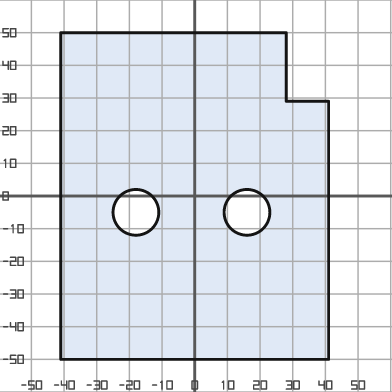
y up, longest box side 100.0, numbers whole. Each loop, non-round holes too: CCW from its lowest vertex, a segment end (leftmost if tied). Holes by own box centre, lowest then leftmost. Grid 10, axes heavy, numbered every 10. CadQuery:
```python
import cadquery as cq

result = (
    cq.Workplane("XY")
    .moveTo(-41.0, -50.0)
    .lineTo(41.0, -50.0)
    .lineTo(41.0, 29.0)
    .lineTo(28.0, 29.0)
    .lineTo(28.0, 50.0)
    .lineTo(-41.0, 50.0)
    .close()
    .moveTo(-18.0, -5.0)
    .circle(7.0)
    .moveTo(16.0, -5.0)
    .circle(7.0)
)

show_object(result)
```